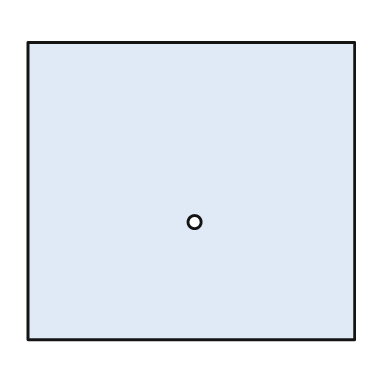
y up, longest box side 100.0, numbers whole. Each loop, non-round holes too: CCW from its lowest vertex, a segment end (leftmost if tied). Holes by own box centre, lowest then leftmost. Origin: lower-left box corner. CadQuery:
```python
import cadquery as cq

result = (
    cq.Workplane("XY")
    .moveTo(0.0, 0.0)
    .lineTo(100.0, 0.0)
    .lineTo(100.0, 91.0)
    .lineTo(0.0, 91.0)
    .close()
    .moveTo(51.0, 36.0)
    .circle(2.0)
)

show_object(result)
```